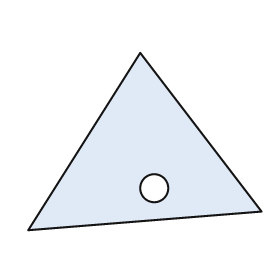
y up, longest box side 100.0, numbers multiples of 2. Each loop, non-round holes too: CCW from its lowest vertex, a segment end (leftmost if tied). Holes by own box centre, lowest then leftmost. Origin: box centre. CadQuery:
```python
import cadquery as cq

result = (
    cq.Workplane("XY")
    .moveTo(-50.0, -38.0)
    .lineTo(50.0, -30.0)
    .lineTo(-2.0, 38.0)
    .close()
    .moveTo(4.0, -20.0)
    .circle(6.0)
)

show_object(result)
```